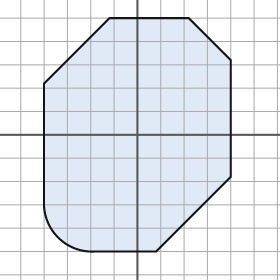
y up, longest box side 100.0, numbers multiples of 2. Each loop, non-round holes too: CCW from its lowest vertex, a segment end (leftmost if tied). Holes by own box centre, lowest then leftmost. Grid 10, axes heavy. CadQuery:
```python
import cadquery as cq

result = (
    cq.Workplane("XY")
    .moveTo(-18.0, -50.0)
    .lineTo(8.0, -50.0)
    .lineTo(40.0, -18.0)
    .lineTo(40.0, 32.0)
    .lineTo(22.0, 50.0)
    .lineTo(-12.0, 50.0)
    .lineTo(-40.0, 22.0)
    .lineTo(-40.0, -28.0)
    .threePointArc((-34.0, -44.0), (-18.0, -50.0))
    .close()
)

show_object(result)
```